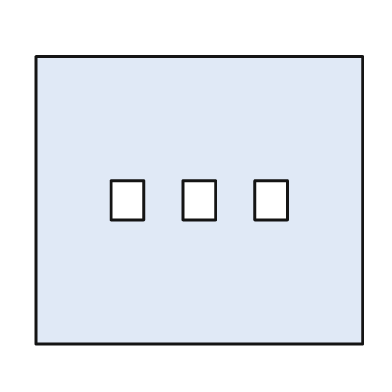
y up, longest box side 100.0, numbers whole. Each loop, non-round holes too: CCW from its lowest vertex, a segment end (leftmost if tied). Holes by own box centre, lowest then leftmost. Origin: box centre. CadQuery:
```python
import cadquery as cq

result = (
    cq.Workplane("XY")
    .moveTo(-50.0, -44.0)
    .lineTo(50.0, -44.0)
    .lineTo(50.0, 44.0)
    .lineTo(-50.0, 44.0)
    .close()
    .moveTo(-27.0, -6.0)
    .lineTo(-17.0, -6.0)
    .lineTo(-17.0, 6.0)
    .lineTo(-27.0, 6.0)
    .close()
    .moveTo(-5.0, -6.0)
    .lineTo(5.0, -6.0)
    .lineTo(5.0, 6.0)
    .lineTo(-5.0, 6.0)
    .close()
    .moveTo(17.0, -6.0)
    .lineTo(27.0, -6.0)
    .lineTo(27.0, 6.0)
    .lineTo(17.0, 6.0)
    .close()
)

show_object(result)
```